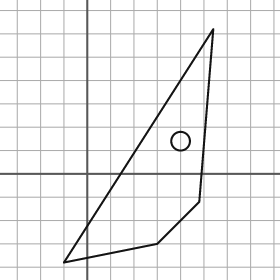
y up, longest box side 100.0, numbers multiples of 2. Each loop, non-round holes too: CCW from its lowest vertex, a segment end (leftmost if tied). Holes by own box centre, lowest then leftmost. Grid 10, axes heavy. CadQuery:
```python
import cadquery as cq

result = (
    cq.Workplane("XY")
    .moveTo(-10.0, -38.0)
    .lineTo(30.0, -30.0)
    .lineTo(48.0, -12.0)
    .lineTo(54.0, 62.0)
    .close()
    .moveTo(40.0, 14.0)
    .circle(4.0)
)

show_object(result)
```